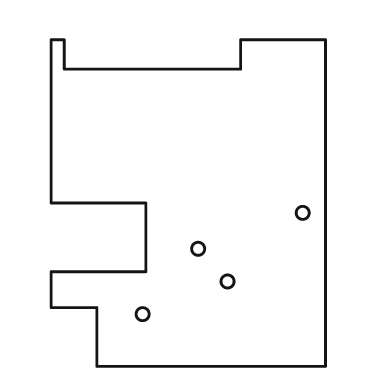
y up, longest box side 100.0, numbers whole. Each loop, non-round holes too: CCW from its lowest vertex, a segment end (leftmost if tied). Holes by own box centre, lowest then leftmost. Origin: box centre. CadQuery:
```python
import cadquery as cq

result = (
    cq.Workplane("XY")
    .moveTo(-28.0, -50.0)
    .lineTo(42.0, -50.0)
    .lineTo(42.0, 50.0)
    .lineTo(16.0, 50.0)
    .lineTo(16.0, 41.0)
    .lineTo(-38.0, 41.0)
    .lineTo(-38.0, 50.0)
    .lineTo(-42.0, 50.0)
    .lineTo(-42.0, 0.0)
    .lineTo(-13.0, 0.0)
    .lineTo(-13.0, -21.0)
    .lineTo(-42.0, -21.0)
    .lineTo(-42.0, -32.0)
    .lineTo(-28.0, -32.0)
    .close()
    .moveTo(-14.0, -34.0)
    .circle(2.0)
    .moveTo(12.0, -24.0)
    .circle(2.0)
    .moveTo(3.0, -14.0)
    .circle(2.0)
    .moveTo(35.0, -3.0)
    .circle(2.0)
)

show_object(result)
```